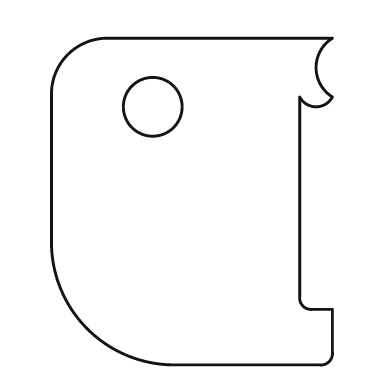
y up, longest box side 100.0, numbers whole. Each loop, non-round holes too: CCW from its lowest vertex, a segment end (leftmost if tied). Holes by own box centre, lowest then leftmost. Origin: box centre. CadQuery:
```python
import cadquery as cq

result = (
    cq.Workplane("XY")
    .moveTo(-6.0, -50.0)
    .lineTo(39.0, -50.0)
    .threePointArc((42.0, -49.0), (43.0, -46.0))
    .lineTo(43.0, -33.0)
    .lineTo(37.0, -33.0)
    .threePointArc((34.0, -32.0), (33.0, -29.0))
    .lineTo(33.0, 32.0)
    .threePointArc((38.0, 29.0), (43.0, 32.0))
    .threePointArc((38.0, 41.0), (43.0, 50.0))
    .lineTo(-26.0, 50.0)
    .threePointArc((-38.0, 45.0), (-43.0, 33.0))
    .lineTo(-43.0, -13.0)
    .threePointArc((-32.0, -39.0), (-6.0, -50.0))
    .close()
    .moveTo(-12.0, 29.0)
    .circle(9.0)
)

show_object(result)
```